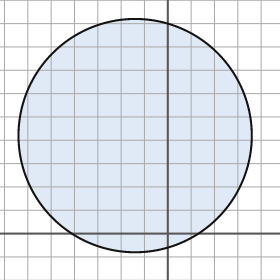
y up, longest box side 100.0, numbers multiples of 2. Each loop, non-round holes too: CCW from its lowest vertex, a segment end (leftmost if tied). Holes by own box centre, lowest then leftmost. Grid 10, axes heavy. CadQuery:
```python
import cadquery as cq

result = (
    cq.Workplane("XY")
    .moveTo(-14.0, 42.0)
    .circle(50.0)
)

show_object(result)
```